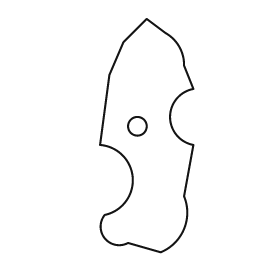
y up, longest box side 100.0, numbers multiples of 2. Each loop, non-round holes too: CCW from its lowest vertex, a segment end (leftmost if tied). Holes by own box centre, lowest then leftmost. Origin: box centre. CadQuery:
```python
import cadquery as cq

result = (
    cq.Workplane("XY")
    .moveTo(6.0, -50.0)
    .threePointArc((16.0, -40.0), (16.0, -26.0))
    .lineTo(20.0, -4.0)
    .threePointArc((10.0, 8.0), (20.0, 20.0))
    .lineTo(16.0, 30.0)
    .threePointArc((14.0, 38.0), (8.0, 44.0))
    .lineTo(0.0, 50.0)
    .lineTo(-10.0, 40.0)
    .lineTo(-16.0, 26.0)
    .lineTo(-20.0, -4.0)
    .threePointArc((-6.0, -18.0), (-18.0, -34.0))
    .threePointArc((-18.0, -44.0), (-8.0, -46.0))
    .close()
    .moveTo(-4.0, 4.0)
    .circle(4.0)
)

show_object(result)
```